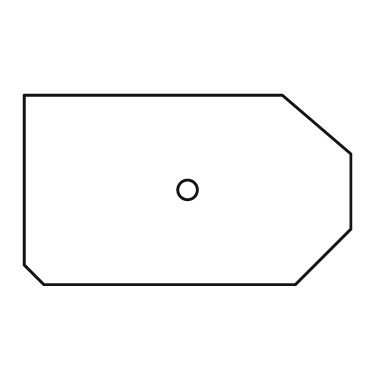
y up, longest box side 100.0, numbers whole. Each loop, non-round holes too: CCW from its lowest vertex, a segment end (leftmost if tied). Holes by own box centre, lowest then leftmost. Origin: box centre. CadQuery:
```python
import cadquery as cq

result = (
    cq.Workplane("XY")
    .moveTo(-44.0, -29.0)
    .lineTo(33.0, -29.0)
    .lineTo(50.0, -12.0)
    .lineTo(50.0, 11.0)
    .lineTo(29.0, 29.0)
    .lineTo(-50.0, 29.0)
    .lineTo(-50.0, -23.0)
    .close()
    .moveTo(0.0, 0.0)
    .circle(3.0)
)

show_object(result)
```